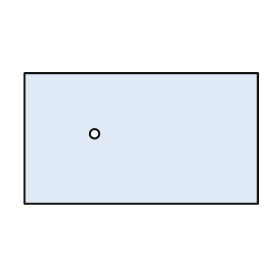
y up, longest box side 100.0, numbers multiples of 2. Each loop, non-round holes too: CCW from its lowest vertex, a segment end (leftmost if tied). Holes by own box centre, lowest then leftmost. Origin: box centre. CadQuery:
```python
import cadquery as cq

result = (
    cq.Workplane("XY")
    .moveTo(-50.0, -28.0)
    .lineTo(50.0, -28.0)
    .lineTo(50.0, 28.0)
    .lineTo(-50.0, 28.0)
    .close()
    .moveTo(-20.0, 2.0)
    .circle(2.0)
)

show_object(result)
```